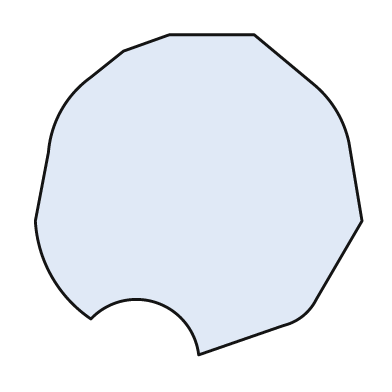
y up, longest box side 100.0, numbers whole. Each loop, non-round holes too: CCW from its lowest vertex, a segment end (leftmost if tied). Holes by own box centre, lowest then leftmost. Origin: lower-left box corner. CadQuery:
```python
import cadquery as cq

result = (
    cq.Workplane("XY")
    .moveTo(50.0, 0.0)
    .lineTo(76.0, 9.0)
    .threePointArc((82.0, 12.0), (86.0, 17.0))
    .lineTo(100.0, 41.0)
    .lineTo(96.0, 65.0)
    .threePointArc((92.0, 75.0), (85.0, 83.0))
    .lineTo(67.0, 98.0)
    .lineTo(41.0, 98.0)
    .lineTo(27.0, 93.0)
    .lineTo(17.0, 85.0)
    .threePointArc((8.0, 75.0), (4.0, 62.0))
    .lineTo(0.0, 41.0)
    .threePointArc((5.0, 24.0), (17.0, 11.0))
    .threePointArc((37.0, 16.0), (50.0, 0.0))
    .close()
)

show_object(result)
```